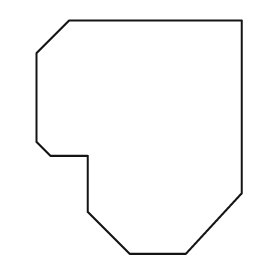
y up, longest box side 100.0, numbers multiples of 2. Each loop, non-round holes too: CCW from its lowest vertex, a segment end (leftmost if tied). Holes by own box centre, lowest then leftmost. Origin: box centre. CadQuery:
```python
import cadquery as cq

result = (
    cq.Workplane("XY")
    .moveTo(-4.0, -50.0)
    .lineTo(20.0, -50.0)
    .lineTo(44.0, -24.0)
    .lineTo(44.0, 50.0)
    .lineTo(-30.0, 50.0)
    .lineTo(-44.0, 36.0)
    .lineTo(-44.0, -2.0)
    .lineTo(-38.0, -8.0)
    .lineTo(-22.0, -8.0)
    .lineTo(-22.0, -32.0)
    .close()
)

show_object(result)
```